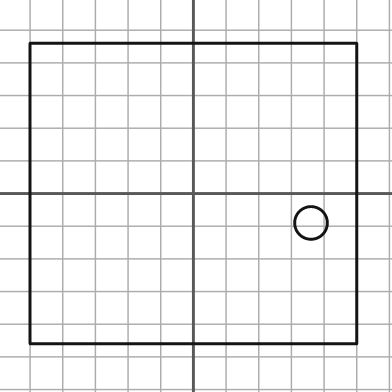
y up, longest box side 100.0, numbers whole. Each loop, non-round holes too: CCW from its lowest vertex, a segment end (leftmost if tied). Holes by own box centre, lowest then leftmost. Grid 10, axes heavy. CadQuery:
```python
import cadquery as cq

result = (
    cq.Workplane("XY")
    .moveTo(-50.0, -46.0)
    .lineTo(50.0, -46.0)
    .lineTo(50.0, 46.0)
    .lineTo(-50.0, 46.0)
    .close()
    .moveTo(36.0, -9.0)
    .circle(5.0)
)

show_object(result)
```